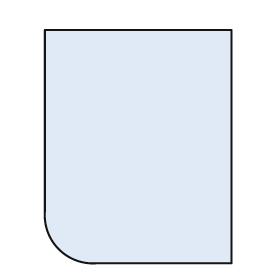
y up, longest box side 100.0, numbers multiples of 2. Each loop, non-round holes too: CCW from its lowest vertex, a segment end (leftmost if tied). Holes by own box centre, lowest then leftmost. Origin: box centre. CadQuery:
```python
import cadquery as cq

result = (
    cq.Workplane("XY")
    .moveTo(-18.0, -50.0)
    .lineTo(40.0, -50.0)
    .lineTo(40.0, 50.0)
    .lineTo(-40.0, 50.0)
    .lineTo(-40.0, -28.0)
    .threePointArc((-34.0, -44.0), (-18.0, -50.0))
    .close()
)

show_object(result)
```